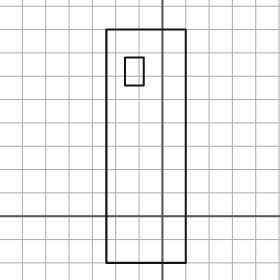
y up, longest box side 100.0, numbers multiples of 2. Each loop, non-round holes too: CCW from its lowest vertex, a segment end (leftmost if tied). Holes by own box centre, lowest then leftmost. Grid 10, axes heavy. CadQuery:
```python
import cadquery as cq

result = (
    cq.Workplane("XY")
    .moveTo(-24.0, -20.0)
    .lineTo(10.0, -20.0)
    .lineTo(10.0, 80.0)
    .lineTo(-24.0, 80.0)
    .close()
    .moveTo(-16.0, 56.0)
    .lineTo(-8.0, 56.0)
    .lineTo(-8.0, 68.0)
    .lineTo(-16.0, 68.0)
    .close()
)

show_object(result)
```